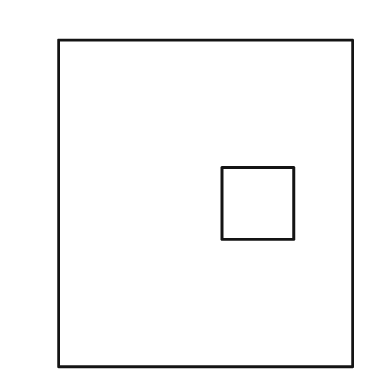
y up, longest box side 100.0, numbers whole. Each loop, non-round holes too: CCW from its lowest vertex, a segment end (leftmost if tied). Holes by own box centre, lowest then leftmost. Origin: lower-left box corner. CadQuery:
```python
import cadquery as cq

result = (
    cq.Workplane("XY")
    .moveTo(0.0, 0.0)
    .lineTo(90.0, 0.0)
    .lineTo(90.0, 100.0)
    .lineTo(0.0, 100.0)
    .close()
    .moveTo(50.0, 39.0)
    .lineTo(72.0, 39.0)
    .lineTo(72.0, 61.0)
    .lineTo(50.0, 61.0)
    .close()
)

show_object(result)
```